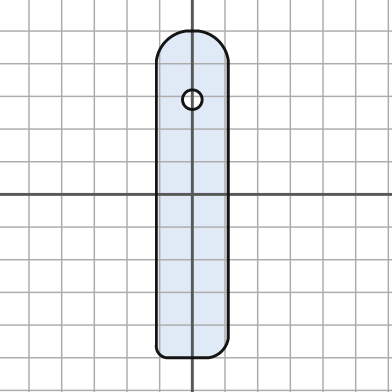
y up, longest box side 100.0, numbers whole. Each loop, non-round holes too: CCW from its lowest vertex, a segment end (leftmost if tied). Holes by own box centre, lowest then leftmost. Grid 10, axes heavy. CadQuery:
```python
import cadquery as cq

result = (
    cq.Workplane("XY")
    .moveTo(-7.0, -50.0)
    .lineTo(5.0, -50.0)
    .threePointArc((9.0, -48.0), (11.0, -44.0))
    .lineTo(11.0, 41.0)
    .threePointArc((8.0, 47.0), (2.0, 50.0))
    .lineTo(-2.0, 50.0)
    .threePointArc((-8.0, 47.0), (-11.0, 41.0))
    .lineTo(-11.0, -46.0)
    .threePointArc((-10.0, -49.0), (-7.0, -50.0))
    .close()
    .moveTo(0.0, 29.0)
    .circle(3.0)
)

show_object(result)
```